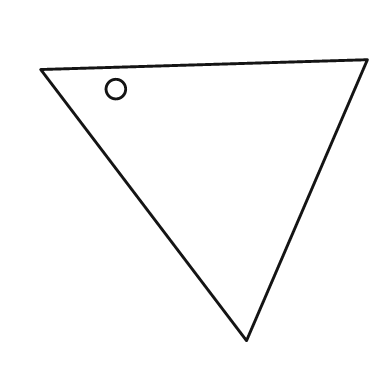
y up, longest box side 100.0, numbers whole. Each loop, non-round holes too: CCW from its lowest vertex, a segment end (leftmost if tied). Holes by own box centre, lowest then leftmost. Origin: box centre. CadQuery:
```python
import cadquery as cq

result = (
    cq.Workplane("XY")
    .moveTo(13.0, -43.0)
    .lineTo(50.0, 43.0)
    .lineTo(-50.0, 40.0)
    .close()
    .moveTo(-27.0, 34.0)
    .circle(3.0)
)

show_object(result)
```